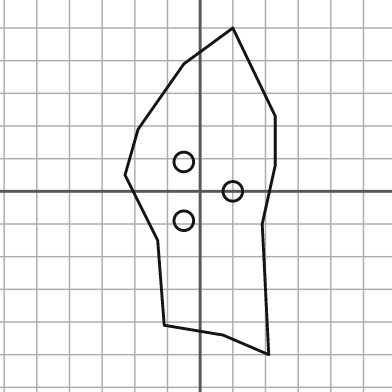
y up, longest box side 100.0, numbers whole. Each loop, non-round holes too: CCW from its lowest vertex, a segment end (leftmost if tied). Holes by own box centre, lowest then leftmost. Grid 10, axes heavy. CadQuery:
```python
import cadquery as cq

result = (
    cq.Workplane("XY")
    .moveTo(21.0, -50.0)
    .lineTo(19.0, -10.0)
    .lineTo(23.0, 8.0)
    .lineTo(23.0, 23.0)
    .lineTo(10.0, 50.0)
    .lineTo(-5.0, 39.0)
    .lineTo(-19.0, 19.0)
    .lineTo(-23.0, 5.0)
    .lineTo(-13.0, -15.0)
    .lineTo(-11.0, -41.0)
    .lineTo(7.0, -44.0)
    .close()
    .moveTo(-5.0, -9.0)
    .circle(3.0)
    .moveTo(10.0, 0.0)
    .circle(3.0)
    .moveTo(-5.0, 9.0)
    .circle(3.0)
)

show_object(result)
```